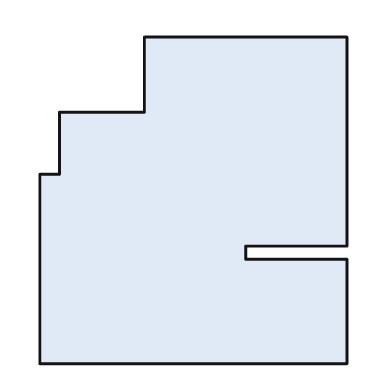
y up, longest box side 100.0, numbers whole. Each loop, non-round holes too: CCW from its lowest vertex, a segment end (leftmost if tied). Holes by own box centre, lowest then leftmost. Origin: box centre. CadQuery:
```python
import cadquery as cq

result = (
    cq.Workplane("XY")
    .moveTo(-47.0, -50.0)
    .lineTo(47.0, -50.0)
    .lineTo(47.0, -18.0)
    .lineTo(16.0, -18.0)
    .lineTo(16.0, -14.0)
    .lineTo(47.0, -14.0)
    .lineTo(47.0, 50.0)
    .lineTo(-15.0, 50.0)
    .lineTo(-15.0, 27.0)
    .lineTo(-41.0, 27.0)
    .lineTo(-41.0, 8.0)
    .lineTo(-47.0, 8.0)
    .close()
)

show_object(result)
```